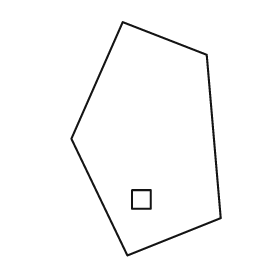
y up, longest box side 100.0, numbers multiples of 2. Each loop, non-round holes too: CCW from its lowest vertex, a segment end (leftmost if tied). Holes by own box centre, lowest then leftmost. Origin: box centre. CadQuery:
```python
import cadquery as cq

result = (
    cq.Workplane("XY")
    .moveTo(-8.0, -50.0)
    .lineTo(32.0, -34.0)
    .lineTo(26.0, 36.0)
    .lineTo(-10.0, 50.0)
    .lineTo(-32.0, 0.0)
    .close()
    .moveTo(-6.0, -30.0)
    .lineTo(2.0, -30.0)
    .lineTo(2.0, -22.0)
    .lineTo(-6.0, -22.0)
    .close()
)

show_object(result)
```